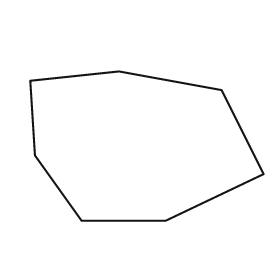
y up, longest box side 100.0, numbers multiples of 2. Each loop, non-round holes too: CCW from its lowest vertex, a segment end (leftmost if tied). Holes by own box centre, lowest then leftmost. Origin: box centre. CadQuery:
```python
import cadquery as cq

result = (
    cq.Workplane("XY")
    .moveTo(-28.0, -32.0)
    .lineTo(8.0, -32.0)
    .lineTo(50.0, -12.0)
    .lineTo(32.0, 24.0)
    .lineTo(-12.0, 32.0)
    .lineTo(-50.0, 28.0)
    .lineTo(-48.0, -4.0)
    .close()
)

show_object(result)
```